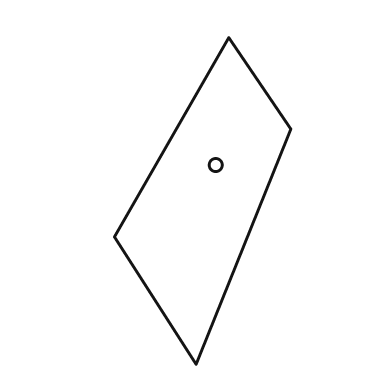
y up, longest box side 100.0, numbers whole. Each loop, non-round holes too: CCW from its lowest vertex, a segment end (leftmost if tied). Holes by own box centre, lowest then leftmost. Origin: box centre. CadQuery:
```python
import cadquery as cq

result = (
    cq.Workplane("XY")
    .moveTo(-2.0, -50.0)
    .lineTo(27.0, 22.0)
    .lineTo(8.0, 50.0)
    .lineTo(-27.0, -11.0)
    .close()
    .moveTo(4.0, 11.0)
    .circle(2.0)
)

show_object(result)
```